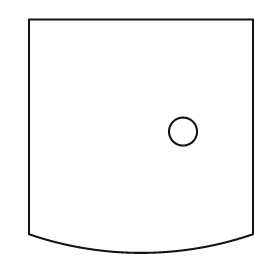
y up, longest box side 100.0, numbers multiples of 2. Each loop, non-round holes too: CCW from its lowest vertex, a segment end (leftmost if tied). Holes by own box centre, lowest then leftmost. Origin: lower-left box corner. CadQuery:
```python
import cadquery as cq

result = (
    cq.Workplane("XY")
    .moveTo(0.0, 8.0)
    .threePointArc((48.0, 0.0), (96.0, 8.0))
    .lineTo(96.0, 100.0)
    .lineTo(0.0, 100.0)
    .close()
    .moveTo(66.0, 52.0)
    .circle(6.0)
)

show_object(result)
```